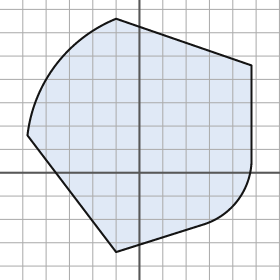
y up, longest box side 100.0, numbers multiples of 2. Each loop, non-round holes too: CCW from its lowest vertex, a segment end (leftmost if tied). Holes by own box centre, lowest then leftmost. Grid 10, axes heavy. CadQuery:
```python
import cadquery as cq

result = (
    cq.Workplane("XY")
    .moveTo(-10.0, -34.0)
    .lineTo(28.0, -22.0)
    .threePointArc((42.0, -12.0), (48.0, 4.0))
    .lineTo(48.0, 46.0)
    .lineTo(-10.0, 66.0)
    .threePointArc((-36.0, 46.0), (-48.0, 16.0))
    .close()
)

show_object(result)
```